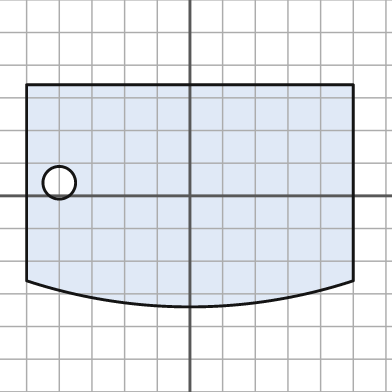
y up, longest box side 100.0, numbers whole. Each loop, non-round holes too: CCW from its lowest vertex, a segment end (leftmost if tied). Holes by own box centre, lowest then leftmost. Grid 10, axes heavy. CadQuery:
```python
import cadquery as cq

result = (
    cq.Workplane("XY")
    .moveTo(-50.0, -26.0)
    .threePointArc((0.0, -34.0), (50.0, -26.0))
    .lineTo(50.0, 34.0)
    .lineTo(-50.0, 34.0)
    .close()
    .moveTo(-40.0, 4.0)
    .circle(5.0)
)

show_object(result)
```